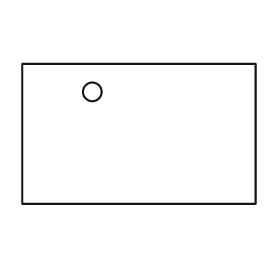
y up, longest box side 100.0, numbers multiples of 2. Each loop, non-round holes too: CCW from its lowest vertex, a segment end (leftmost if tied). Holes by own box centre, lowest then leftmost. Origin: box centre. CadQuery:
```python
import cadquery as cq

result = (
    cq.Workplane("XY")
    .moveTo(-50.0, -30.0)
    .lineTo(50.0, -30.0)
    .lineTo(50.0, 30.0)
    .lineTo(-50.0, 30.0)
    .close()
    .moveTo(-20.0, 18.0)
    .circle(4.0)
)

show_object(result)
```